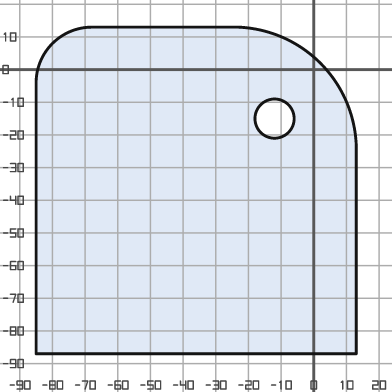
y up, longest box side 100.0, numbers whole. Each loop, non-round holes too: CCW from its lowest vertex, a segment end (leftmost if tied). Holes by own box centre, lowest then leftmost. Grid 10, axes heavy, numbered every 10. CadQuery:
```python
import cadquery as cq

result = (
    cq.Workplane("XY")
    .moveTo(-85.0, -87.0)
    .lineTo(13.0, -87.0)
    .lineTo(13.0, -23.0)
    .threePointArc((2.0, 2.0), (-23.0, 13.0))
    .lineTo(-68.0, 13.0)
    .threePointArc((-80.0, 8.0), (-85.0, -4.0))
    .close()
    .moveTo(-12.0, -15.0)
    .circle(6.0)
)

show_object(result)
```